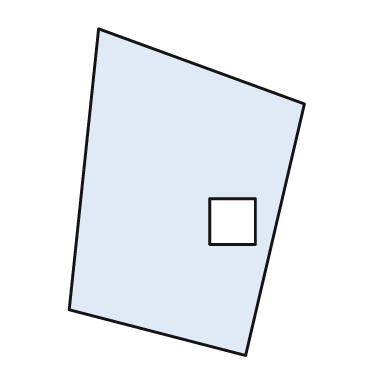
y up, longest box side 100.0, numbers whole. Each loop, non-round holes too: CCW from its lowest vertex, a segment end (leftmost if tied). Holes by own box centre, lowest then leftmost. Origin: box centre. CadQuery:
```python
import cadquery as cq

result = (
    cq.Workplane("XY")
    .moveTo(18.0, -50.0)
    .lineTo(36.0, 27.0)
    .lineTo(-27.0, 50.0)
    .lineTo(-36.0, -36.0)
    .close()
    .moveTo(7.0, -16.0)
    .lineTo(21.0, -16.0)
    .lineTo(21.0, -2.0)
    .lineTo(7.0, -2.0)
    .close()
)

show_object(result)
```